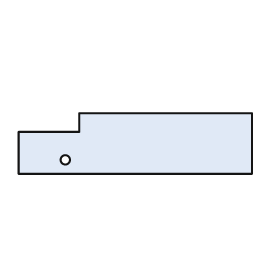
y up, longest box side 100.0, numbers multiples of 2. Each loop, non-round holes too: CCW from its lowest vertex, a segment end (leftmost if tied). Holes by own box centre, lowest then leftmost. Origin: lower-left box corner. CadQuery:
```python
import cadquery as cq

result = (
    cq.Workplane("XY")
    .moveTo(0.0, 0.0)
    .lineTo(100.0, 0.0)
    .lineTo(100.0, 26.0)
    .lineTo(26.0, 26.0)
    .lineTo(26.0, 18.0)
    .lineTo(0.0, 18.0)
    .close()
    .moveTo(20.0, 6.0)
    .circle(2.0)
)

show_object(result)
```